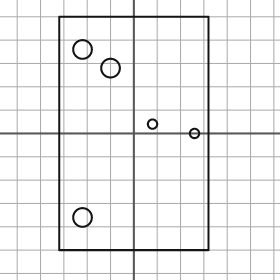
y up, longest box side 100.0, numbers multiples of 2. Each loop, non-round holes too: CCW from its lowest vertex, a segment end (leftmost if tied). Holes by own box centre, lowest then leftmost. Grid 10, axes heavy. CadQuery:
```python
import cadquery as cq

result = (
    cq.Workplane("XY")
    .moveTo(-32.0, -50.0)
    .lineTo(32.0, -50.0)
    .lineTo(32.0, 50.0)
    .lineTo(-32.0, 50.0)
    .close()
    .moveTo(-22.0, -36.0)
    .circle(4.0)
    .moveTo(26.0, 0.0)
    .circle(2.0)
    .moveTo(8.0, 4.0)
    .circle(2.0)
    .moveTo(-10.0, 28.0)
    .circle(4.0)
    .moveTo(-22.0, 36.0)
    .circle(4.0)
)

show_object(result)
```